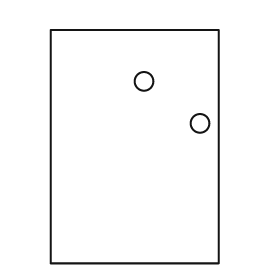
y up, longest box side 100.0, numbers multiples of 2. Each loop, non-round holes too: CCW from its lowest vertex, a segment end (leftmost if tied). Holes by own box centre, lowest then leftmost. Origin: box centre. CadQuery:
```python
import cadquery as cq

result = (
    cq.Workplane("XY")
    .moveTo(-36.0, -50.0)
    .lineTo(36.0, -50.0)
    .lineTo(36.0, 50.0)
    .lineTo(-36.0, 50.0)
    .close()
    .moveTo(28.0, 10.0)
    .circle(4.0)
    .moveTo(4.0, 28.0)
    .circle(4.0)
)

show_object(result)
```